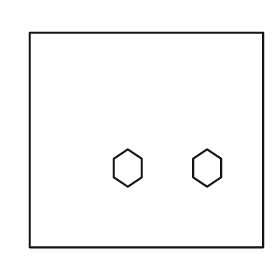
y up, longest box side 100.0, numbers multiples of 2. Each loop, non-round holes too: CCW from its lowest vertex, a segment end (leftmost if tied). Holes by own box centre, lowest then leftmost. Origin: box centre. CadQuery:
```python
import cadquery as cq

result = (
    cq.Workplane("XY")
    .moveTo(-50.0, -46.0)
    .lineTo(50.0, -46.0)
    .lineTo(50.0, 46.0)
    .lineTo(-50.0, 46.0)
    .close()
    .moveTo(-8.0, -20.0)
    .lineTo(-2.0, -16.0)
    .lineTo(-2.0, -8.0)
    .lineTo(-8.0, -4.0)
    .lineTo(-14.0, -8.0)
    .lineTo(-14.0, -16.0)
    .close()
    .moveTo(26.0, -20.0)
    .lineTo(32.0, -16.0)
    .lineTo(32.0, -8.0)
    .lineTo(26.0, -4.0)
    .lineTo(20.0, -8.0)
    .lineTo(20.0, -16.0)
    .close()
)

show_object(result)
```